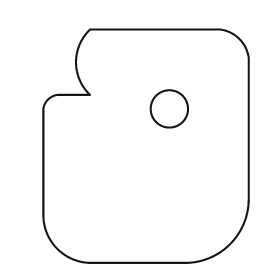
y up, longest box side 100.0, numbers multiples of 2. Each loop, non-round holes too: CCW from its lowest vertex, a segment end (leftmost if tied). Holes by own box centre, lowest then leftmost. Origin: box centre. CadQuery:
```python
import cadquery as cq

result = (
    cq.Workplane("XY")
    .moveTo(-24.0, -50.0)
    .lineTo(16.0, -50.0)
    .threePointArc((36.0, -42.0), (44.0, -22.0))
    .lineTo(44.0, 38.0)
    .threePointArc((40.0, 46.0), (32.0, 50.0))
    .lineTo(-24.0, 50.0)
    .threePointArc((-30.0, 36.0), (-24.0, 22.0))
    .lineTo(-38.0, 22.0)
    .threePointArc((-42.0, 20.0), (-44.0, 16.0))
    .lineTo(-44.0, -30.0)
    .threePointArc((-38.0, -44.0), (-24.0, -50.0))
    .close()
    .moveTo(10.0, 16.0)
    .circle(8.0)
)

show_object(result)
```